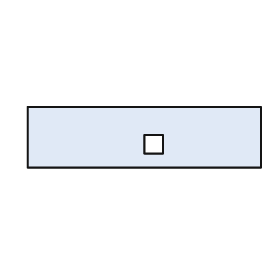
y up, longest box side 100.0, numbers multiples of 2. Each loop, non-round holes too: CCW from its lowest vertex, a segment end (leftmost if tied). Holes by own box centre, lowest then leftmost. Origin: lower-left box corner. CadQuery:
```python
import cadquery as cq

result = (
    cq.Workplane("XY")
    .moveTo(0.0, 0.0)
    .lineTo(100.0, 0.0)
    .lineTo(100.0, 26.0)
    .lineTo(0.0, 26.0)
    .close()
    .moveTo(50.0, 6.0)
    .lineTo(58.0, 6.0)
    .lineTo(58.0, 14.0)
    .lineTo(50.0, 14.0)
    .close()
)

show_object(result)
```